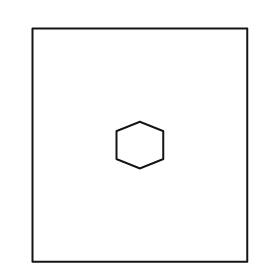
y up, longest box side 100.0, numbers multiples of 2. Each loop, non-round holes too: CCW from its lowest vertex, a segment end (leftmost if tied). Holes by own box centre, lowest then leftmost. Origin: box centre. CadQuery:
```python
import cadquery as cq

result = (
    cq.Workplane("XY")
    .moveTo(-46.0, -50.0)
    .lineTo(46.0, -50.0)
    .lineTo(46.0, 50.0)
    .lineTo(-46.0, 50.0)
    .close()
    .moveTo(0.0, -10.0)
    .lineTo(10.0, -6.0)
    .lineTo(10.0, 6.0)
    .lineTo(0.0, 10.0)
    .lineTo(-10.0, 6.0)
    .lineTo(-10.0, -6.0)
    .close()
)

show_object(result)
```